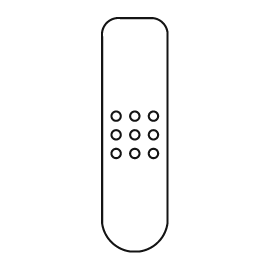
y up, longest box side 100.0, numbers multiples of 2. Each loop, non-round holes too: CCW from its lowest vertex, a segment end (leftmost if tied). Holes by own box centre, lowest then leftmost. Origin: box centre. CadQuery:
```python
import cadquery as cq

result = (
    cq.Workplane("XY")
    .moveTo(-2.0, -50.0)
    .lineTo(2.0, -50.0)
    .threePointArc((10.0, -46.0), (14.0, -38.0))
    .lineTo(14.0, 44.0)
    .threePointArc((12.0, 48.0), (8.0, 50.0))
    .lineTo(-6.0, 50.0)
    .threePointArc((-12.0, 48.0), (-14.0, 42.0))
    .lineTo(-14.0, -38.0)
    .threePointArc((-10.0, -46.0), (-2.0, -50.0))
    .close()
    .moveTo(-8.0, -8.0)
    .circle(2.0)
    .moveTo(0.0, -8.0)
    .circle(2.0)
    .moveTo(8.0, -8.0)
    .circle(2.0)
    .moveTo(-8.0, 0.0)
    .circle(2.0)
    .moveTo(0.0, 0.0)
    .circle(2.0)
    .moveTo(8.0, 0.0)
    .circle(2.0)
    .moveTo(-8.0, 8.0)
    .circle(2.0)
    .moveTo(0.0, 8.0)
    .circle(2.0)
    .moveTo(8.0, 8.0)
    .circle(2.0)
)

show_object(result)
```